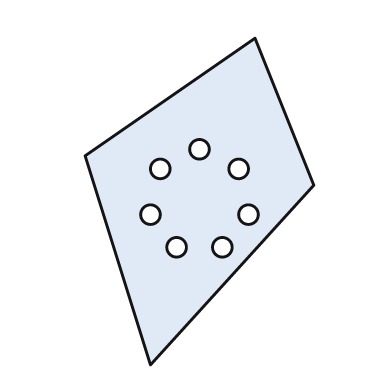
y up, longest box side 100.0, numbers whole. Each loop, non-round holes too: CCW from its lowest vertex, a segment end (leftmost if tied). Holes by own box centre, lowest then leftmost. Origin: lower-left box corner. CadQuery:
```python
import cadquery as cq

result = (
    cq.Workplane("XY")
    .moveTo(20.0, 0.0)
    .lineTo(70.0, 55.0)
    .lineTo(52.0, 100.0)
    .lineTo(0.0, 64.0)
    .close()
    .moveTo(28.0, 36.0)
    .circle(3.0)
    .moveTo(42.0, 36.0)
    .circle(3.0)
    .moveTo(20.0, 46.0)
    .circle(3.0)
    .moveTo(50.0, 46.0)
    .circle(3.0)
    .moveTo(23.0, 60.0)
    .circle(3.0)
    .moveTo(47.0, 60.0)
    .circle(3.0)
    .moveTo(35.0, 66.0)
    .circle(3.0)
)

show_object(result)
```